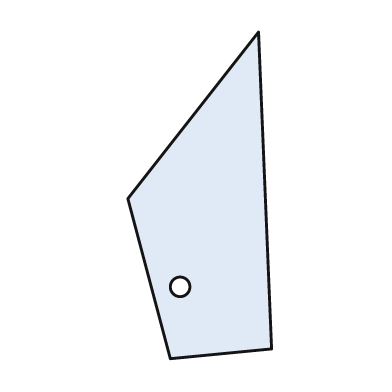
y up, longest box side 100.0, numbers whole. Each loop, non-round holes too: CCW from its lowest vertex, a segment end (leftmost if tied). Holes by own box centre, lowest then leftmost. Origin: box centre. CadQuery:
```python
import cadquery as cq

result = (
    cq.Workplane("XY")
    .moveTo(-9.0, -50.0)
    .lineTo(22.0, -47.0)
    .lineTo(18.0, 50.0)
    .lineTo(-22.0, -1.0)
    .close()
    .moveTo(-6.0, -28.0)
    .circle(3.0)
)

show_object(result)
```